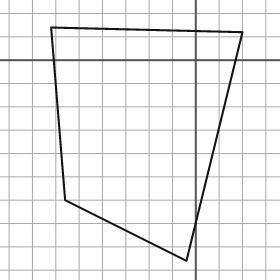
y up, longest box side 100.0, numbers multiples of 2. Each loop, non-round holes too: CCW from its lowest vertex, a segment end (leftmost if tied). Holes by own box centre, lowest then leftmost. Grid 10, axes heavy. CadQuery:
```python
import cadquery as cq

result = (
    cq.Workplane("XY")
    .moveTo(-4.0, -86.0)
    .lineTo(20.0, 12.0)
    .lineTo(-62.0, 14.0)
    .lineTo(-56.0, -60.0)
    .close()
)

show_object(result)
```